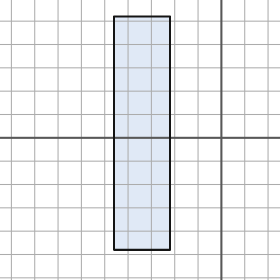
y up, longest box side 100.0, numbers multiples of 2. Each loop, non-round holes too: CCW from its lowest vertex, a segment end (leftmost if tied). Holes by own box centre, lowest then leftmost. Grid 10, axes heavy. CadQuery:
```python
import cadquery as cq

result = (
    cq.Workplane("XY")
    .moveTo(-46.0, -48.0)
    .lineTo(-22.0, -48.0)
    .lineTo(-22.0, 52.0)
    .lineTo(-46.0, 52.0)
    .close()
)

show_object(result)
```